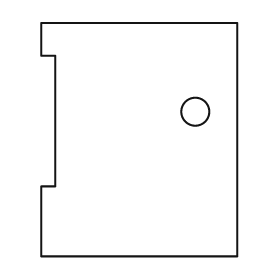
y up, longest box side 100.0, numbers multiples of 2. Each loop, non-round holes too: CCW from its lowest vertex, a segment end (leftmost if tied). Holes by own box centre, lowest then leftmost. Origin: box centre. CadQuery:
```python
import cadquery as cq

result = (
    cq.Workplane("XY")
    .moveTo(-42.0, -50.0)
    .lineTo(42.0, -50.0)
    .lineTo(42.0, 50.0)
    .lineTo(-42.0, 50.0)
    .lineTo(-42.0, 36.0)
    .lineTo(-36.0, 36.0)
    .lineTo(-36.0, -20.0)
    .lineTo(-42.0, -20.0)
    .close()
    .moveTo(24.0, 12.0)
    .circle(6.0)
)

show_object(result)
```